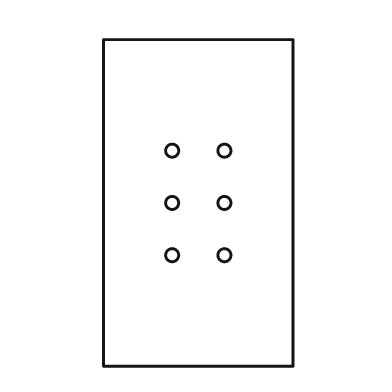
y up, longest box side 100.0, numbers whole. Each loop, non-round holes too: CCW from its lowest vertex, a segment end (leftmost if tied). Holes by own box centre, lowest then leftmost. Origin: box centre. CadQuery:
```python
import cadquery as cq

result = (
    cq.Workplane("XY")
    .moveTo(-29.0, -50.0)
    .lineTo(29.0, -50.0)
    .lineTo(29.0, 50.0)
    .lineTo(-29.0, 50.0)
    .close()
    .moveTo(-8.0, -16.0)
    .circle(2.0)
    .moveTo(8.0, -16.0)
    .circle(2.0)
    .moveTo(-8.0, 0.0)
    .circle(2.0)
    .moveTo(8.0, 0.0)
    .circle(2.0)
    .moveTo(-8.0, 16.0)
    .circle(2.0)
    .moveTo(8.0, 16.0)
    .circle(2.0)
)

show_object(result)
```